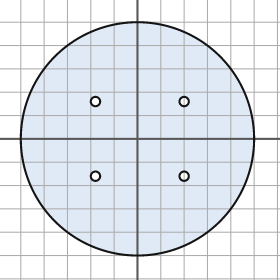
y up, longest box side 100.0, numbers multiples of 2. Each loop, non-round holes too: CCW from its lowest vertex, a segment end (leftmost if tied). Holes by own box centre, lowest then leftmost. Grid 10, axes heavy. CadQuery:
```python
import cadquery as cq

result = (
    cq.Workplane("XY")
    .moveTo(0.0, 0.0)
    .circle(50.0)
    .moveTo(-18.0, -16.0)
    .circle(2.0)
    .moveTo(20.0, -16.0)
    .circle(2.0)
    .moveTo(-18.0, 16.0)
    .circle(2.0)
    .moveTo(20.0, 16.0)
    .circle(2.0)
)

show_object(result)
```